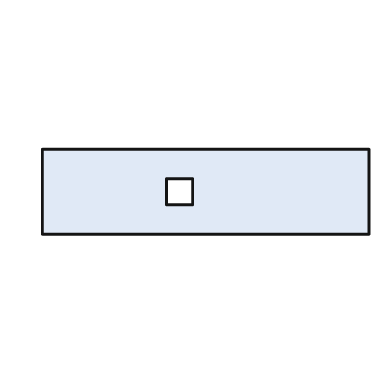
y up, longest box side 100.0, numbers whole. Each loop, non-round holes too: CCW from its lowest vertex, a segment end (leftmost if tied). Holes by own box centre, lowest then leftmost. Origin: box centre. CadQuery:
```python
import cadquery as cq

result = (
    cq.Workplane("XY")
    .moveTo(-50.0, -13.0)
    .lineTo(50.0, -13.0)
    .lineTo(50.0, 13.0)
    .lineTo(-50.0, 13.0)
    .close()
    .moveTo(-12.0, -4.0)
    .lineTo(-4.0, -4.0)
    .lineTo(-4.0, 4.0)
    .lineTo(-12.0, 4.0)
    .close()
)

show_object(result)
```